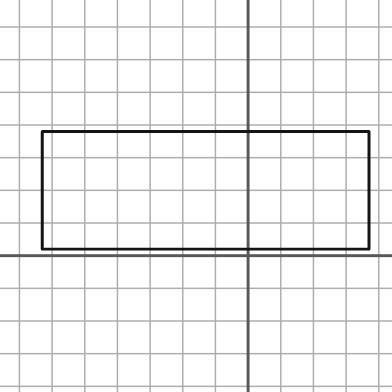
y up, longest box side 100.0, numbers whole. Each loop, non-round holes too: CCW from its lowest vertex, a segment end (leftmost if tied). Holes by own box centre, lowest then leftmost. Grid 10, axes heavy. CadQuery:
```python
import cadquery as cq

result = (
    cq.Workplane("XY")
    .moveTo(-63.0, 2.0)
    .lineTo(37.0, 2.0)
    .lineTo(37.0, 38.0)
    .lineTo(-63.0, 38.0)
    .close()
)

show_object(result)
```